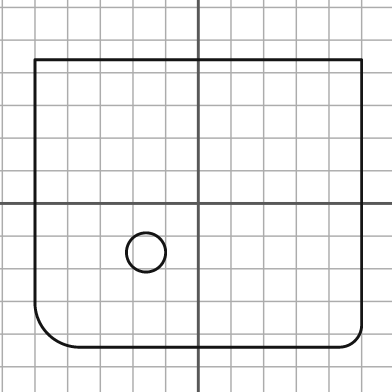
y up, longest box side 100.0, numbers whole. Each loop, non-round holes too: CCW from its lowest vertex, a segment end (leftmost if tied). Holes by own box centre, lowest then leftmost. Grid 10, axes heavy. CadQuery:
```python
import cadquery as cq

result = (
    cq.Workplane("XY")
    .moveTo(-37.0, -44.0)
    .lineTo(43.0, -44.0)
    .threePointArc((48.0, -42.0), (50.0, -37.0))
    .lineTo(50.0, 44.0)
    .lineTo(-50.0, 44.0)
    .lineTo(-50.0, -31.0)
    .threePointArc((-46.0, -40.0), (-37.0, -44.0))
    .close()
    .moveTo(-16.0, -15.0)
    .circle(6.0)
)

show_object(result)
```